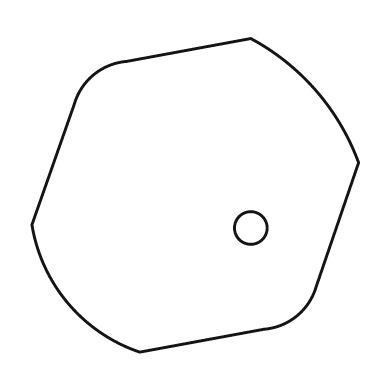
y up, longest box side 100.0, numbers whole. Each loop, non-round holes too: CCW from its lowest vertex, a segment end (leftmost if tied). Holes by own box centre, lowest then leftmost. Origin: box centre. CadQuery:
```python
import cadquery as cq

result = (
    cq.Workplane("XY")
    .moveTo(-17.0, -48.0)
    .lineTo(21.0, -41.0)
    .threePointArc((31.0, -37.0), (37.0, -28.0))
    .lineTo(50.0, 10.0)
    .threePointArc((37.0, 32.0), (17.0, 48.0))
    .lineTo(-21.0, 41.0)
    .threePointArc((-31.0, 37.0), (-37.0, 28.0))
    .lineTo(-50.0, -9.0)
    .threePointArc((-39.0, -33.0), (-17.0, -48.0))
    .close()
    .moveTo(17.0, -10.0)
    .circle(5.0)
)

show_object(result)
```